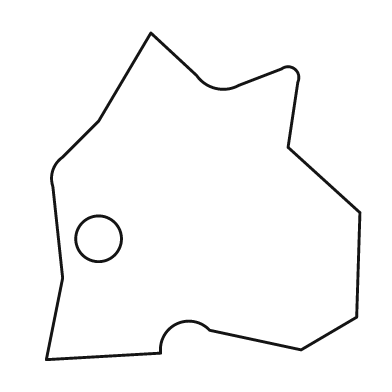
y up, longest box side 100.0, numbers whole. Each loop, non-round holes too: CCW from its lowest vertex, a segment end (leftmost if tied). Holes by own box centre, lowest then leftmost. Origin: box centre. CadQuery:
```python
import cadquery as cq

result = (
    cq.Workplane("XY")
    .moveTo(-48.0, -50.0)
    .lineTo(-13.0, -48.0)
    .threePointArc((-8.0, -39.0), (2.0, -41.0))
    .lineTo(30.0, -47.0)
    .lineTo(47.0, -37.0)
    .lineTo(48.0, -5.0)
    .lineTo(26.0, 15.0)
    .lineTo(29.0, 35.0)
    .threePointArc((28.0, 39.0), (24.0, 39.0))
    .lineTo(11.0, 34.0)
    .threePointArc((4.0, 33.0), (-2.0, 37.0))
    .lineTo(-16.0, 50.0)
    .lineTo(-32.0, 23.0)
    .lineTo(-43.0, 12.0)
    .threePointArc((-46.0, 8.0), (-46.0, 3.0))
    .lineTo(-43.0, -25.0)
    .close()
    .moveTo(-32.0, -13.0)
    .circle(7.0)
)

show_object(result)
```